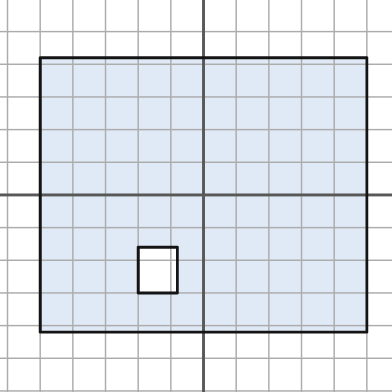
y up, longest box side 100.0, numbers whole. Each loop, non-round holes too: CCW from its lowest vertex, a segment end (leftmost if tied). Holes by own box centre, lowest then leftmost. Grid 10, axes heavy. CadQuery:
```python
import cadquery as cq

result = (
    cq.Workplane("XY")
    .moveTo(-50.0, -42.0)
    .lineTo(50.0, -42.0)
    .lineTo(50.0, 42.0)
    .lineTo(-50.0, 42.0)
    .close()
    .moveTo(-20.0, -30.0)
    .lineTo(-8.0, -30.0)
    .lineTo(-8.0, -16.0)
    .lineTo(-20.0, -16.0)
    .close()
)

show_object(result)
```